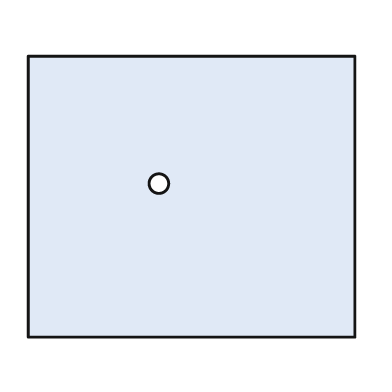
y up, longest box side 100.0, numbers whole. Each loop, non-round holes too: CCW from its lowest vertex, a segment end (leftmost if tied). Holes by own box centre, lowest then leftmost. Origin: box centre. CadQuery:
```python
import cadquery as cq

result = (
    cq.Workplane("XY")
    .moveTo(-50.0, -43.0)
    .lineTo(50.0, -43.0)
    .lineTo(50.0, 43.0)
    .lineTo(-50.0, 43.0)
    .close()
    .moveTo(-10.0, 4.0)
    .circle(3.0)
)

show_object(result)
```